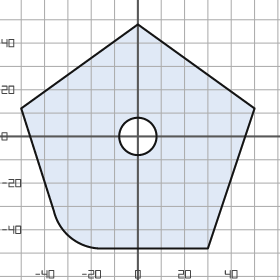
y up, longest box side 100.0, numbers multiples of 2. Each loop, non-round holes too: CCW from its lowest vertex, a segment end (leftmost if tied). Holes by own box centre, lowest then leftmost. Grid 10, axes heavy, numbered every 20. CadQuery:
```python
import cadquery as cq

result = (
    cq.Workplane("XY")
    .moveTo(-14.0, -48.0)
    .lineTo(30.0, -48.0)
    .lineTo(50.0, 12.0)
    .lineTo(0.0, 48.0)
    .lineTo(-50.0, 12.0)
    .lineTo(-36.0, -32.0)
    .threePointArc((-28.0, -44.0), (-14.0, -48.0))
    .close()
    .moveTo(0.0, 0.0)
    .circle(8.0)
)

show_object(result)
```